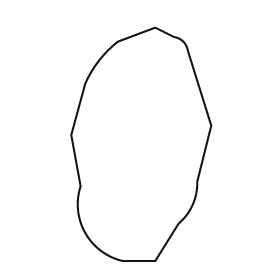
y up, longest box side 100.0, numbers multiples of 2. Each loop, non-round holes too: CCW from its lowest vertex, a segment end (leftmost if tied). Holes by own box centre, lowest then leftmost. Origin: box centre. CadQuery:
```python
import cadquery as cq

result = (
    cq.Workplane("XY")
    .moveTo(-8.0, -50.0)
    .lineTo(6.0, -50.0)
    .lineTo(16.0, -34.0)
    .threePointArc((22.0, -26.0), (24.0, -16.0))
    .lineTo(30.0, 8.0)
    .lineTo(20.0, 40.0)
    .threePointArc((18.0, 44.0), (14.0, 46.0))
    .lineTo(6.0, 50.0)
    .lineTo(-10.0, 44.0)
    .threePointArc((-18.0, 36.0), (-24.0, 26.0))
    .lineTo(-30.0, 4.0)
    .lineTo(-26.0, -18.0)
    .threePointArc((-24.0, -38.0), (-8.0, -50.0))
    .close()
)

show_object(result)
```